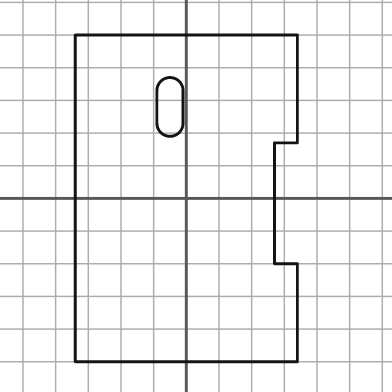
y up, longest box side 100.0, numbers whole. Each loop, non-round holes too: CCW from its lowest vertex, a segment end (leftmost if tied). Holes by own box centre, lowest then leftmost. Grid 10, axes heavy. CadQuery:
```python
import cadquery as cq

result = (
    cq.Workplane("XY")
    .moveTo(-34.0, -50.0)
    .lineTo(34.0, -50.0)
    .lineTo(34.0, -20.0)
    .lineTo(27.0, -20.0)
    .lineTo(27.0, 17.0)
    .lineTo(34.0, 17.0)
    .lineTo(34.0, 50.0)
    .lineTo(-34.0, 50.0)
    .close()
    .moveTo(-9.0, 23.0)
    .threePointArc((-5.0, 19.0), (-1.0, 23.0))
    .lineTo(-1.0, 33.0)
    .threePointArc((-5.0, 37.0), (-9.0, 33.0))
    .close()
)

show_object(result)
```